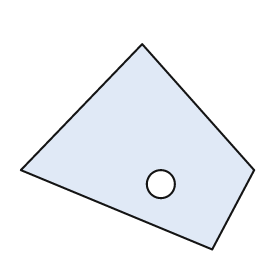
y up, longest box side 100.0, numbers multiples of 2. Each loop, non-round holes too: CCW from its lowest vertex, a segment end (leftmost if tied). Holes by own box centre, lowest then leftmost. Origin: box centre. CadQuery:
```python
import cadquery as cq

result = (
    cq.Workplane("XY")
    .moveTo(32.0, -44.0)
    .lineTo(50.0, -10.0)
    .lineTo(2.0, 44.0)
    .lineTo(-50.0, -10.0)
    .close()
    .moveTo(10.0, -16.0)
    .circle(6.0)
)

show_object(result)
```